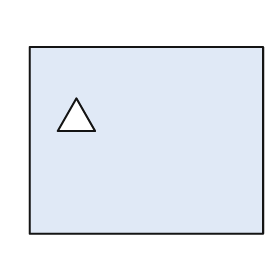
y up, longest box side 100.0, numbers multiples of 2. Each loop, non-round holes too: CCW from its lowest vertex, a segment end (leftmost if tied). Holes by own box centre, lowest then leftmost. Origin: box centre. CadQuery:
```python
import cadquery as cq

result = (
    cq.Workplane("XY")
    .moveTo(-50.0, -40.0)
    .lineTo(50.0, -40.0)
    .lineTo(50.0, 40.0)
    .lineTo(-50.0, 40.0)
    .close()
    .moveTo(-38.0, 4.0)
    .lineTo(-22.0, 4.0)
    .lineTo(-30.0, 18.0)
    .close()
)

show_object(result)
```